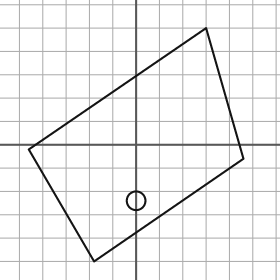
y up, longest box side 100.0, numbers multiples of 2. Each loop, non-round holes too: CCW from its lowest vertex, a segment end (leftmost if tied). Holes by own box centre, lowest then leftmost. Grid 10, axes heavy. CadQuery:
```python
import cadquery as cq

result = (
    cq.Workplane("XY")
    .moveTo(-18.0, -50.0)
    .lineTo(46.0, -6.0)
    .lineTo(30.0, 50.0)
    .lineTo(-46.0, -2.0)
    .close()
    .moveTo(0.0, -24.0)
    .circle(4.0)
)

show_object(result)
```